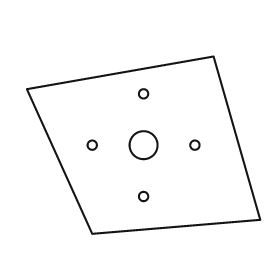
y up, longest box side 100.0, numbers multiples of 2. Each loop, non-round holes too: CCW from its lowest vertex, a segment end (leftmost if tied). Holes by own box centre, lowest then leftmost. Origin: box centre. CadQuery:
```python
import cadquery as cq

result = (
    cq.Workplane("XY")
    .moveTo(-22.0, -38.0)
    .lineTo(50.0, -32.0)
    .lineTo(30.0, 38.0)
    .lineTo(-50.0, 24.0)
    .close()
    .moveTo(0.0, -22.0)
    .circle(2.0)
    .moveTo(-22.0, 0.0)
    .circle(2.0)
    .moveTo(0.0, 0.0)
    .circle(6.0)
    .moveTo(22.0, 0.0)
    .circle(2.0)
    .moveTo(0.0, 22.0)
    .circle(2.0)
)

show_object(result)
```